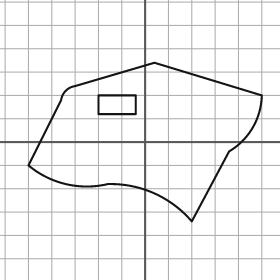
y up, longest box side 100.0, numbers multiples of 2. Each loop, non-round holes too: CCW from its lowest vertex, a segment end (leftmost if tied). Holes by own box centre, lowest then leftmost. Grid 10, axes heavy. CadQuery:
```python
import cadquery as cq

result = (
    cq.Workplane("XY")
    .moveTo(20.0, -34.0)
    .lineTo(36.0, -4.0)
    .threePointArc((46.0, 6.0), (50.0, 20.0))
    .lineTo(4.0, 34.0)
    .lineTo(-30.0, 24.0)
    .threePointArc((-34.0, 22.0), (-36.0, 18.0))
    .lineTo(-50.0, -10.0)
    .threePointArc((-34.0, -18.0), (-16.0, -18.0))
    .threePointArc((4.0, -22.0), (20.0, -34.0))
    .close()
    .moveTo(-20.0, 12.0)
    .lineTo(-4.0, 12.0)
    .lineTo(-4.0, 20.0)
    .lineTo(-20.0, 20.0)
    .close()
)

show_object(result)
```